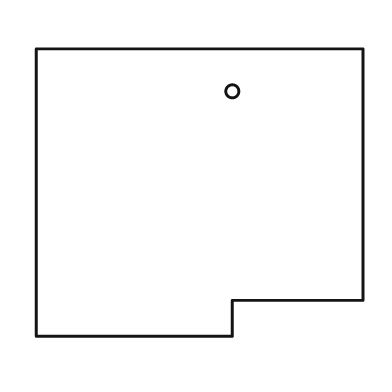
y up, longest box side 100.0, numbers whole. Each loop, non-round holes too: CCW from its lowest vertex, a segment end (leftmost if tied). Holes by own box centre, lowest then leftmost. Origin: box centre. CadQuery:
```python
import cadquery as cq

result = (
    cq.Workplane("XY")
    .moveTo(-50.0, -44.0)
    .lineTo(10.0, -44.0)
    .lineTo(10.0, -33.0)
    .lineTo(50.0, -33.0)
    .lineTo(50.0, 44.0)
    .lineTo(-50.0, 44.0)
    .close()
    .moveTo(10.0, 31.0)
    .circle(2.0)
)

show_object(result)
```